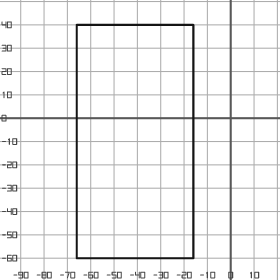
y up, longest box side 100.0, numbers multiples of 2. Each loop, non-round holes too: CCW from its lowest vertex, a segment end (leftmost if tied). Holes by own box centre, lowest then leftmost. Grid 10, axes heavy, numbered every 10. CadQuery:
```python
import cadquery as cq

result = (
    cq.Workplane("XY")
    .moveTo(-66.0, -60.0)
    .lineTo(-16.0, -60.0)
    .lineTo(-16.0, 40.0)
    .lineTo(-66.0, 40.0)
    .close()
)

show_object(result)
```